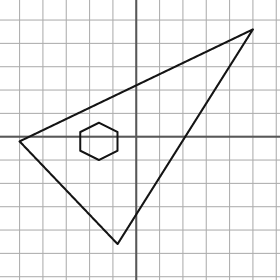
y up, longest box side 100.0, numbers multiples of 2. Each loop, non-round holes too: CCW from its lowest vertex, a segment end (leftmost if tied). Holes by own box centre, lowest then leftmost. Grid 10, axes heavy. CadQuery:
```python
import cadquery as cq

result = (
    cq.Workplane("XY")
    .moveTo(-8.0, -46.0)
    .lineTo(50.0, 46.0)
    .lineTo(-50.0, -2.0)
    .close()
    .moveTo(-16.0, -10.0)
    .lineTo(-8.0, -6.0)
    .lineTo(-8.0, 2.0)
    .lineTo(-16.0, 6.0)
    .lineTo(-24.0, 2.0)
    .lineTo(-24.0, -6.0)
    .close()
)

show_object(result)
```